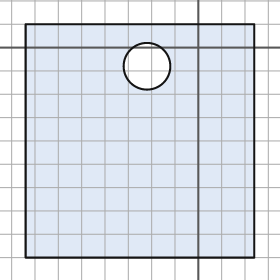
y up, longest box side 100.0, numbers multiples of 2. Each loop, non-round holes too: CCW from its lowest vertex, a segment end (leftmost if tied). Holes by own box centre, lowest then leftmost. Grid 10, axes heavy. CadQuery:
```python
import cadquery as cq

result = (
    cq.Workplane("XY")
    .moveTo(-74.0, -90.0)
    .lineTo(24.0, -90.0)
    .lineTo(24.0, 10.0)
    .lineTo(-74.0, 10.0)
    .close()
    .moveTo(-22.0, -8.0)
    .circle(10.0)
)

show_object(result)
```